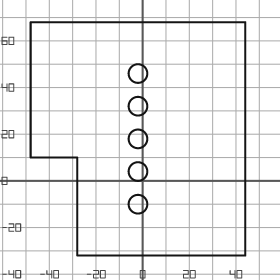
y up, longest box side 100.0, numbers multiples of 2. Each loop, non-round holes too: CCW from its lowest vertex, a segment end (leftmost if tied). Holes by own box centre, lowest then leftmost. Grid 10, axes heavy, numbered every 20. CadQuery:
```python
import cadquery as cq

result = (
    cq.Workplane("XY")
    .moveTo(-28.0, -32.0)
    .lineTo(44.0, -32.0)
    .lineTo(44.0, 68.0)
    .lineTo(-48.0, 68.0)
    .lineTo(-48.0, 10.0)
    .lineTo(-28.0, 10.0)
    .close()
    .moveTo(-2.0, -10.0)
    .circle(4.0)
    .moveTo(-2.0, 4.0)
    .circle(4.0)
    .moveTo(-2.0, 18.0)
    .circle(4.0)
    .moveTo(-2.0, 32.0)
    .circle(4.0)
    .moveTo(-2.0, 46.0)
    .circle(4.0)
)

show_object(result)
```